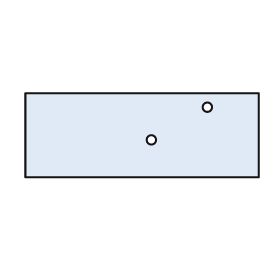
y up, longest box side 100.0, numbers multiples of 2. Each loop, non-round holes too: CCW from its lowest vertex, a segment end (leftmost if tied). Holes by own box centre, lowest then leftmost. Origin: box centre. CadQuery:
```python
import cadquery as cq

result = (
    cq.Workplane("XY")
    .moveTo(-50.0, -18.0)
    .lineTo(50.0, -18.0)
    .lineTo(50.0, 18.0)
    .lineTo(-50.0, 18.0)
    .close()
    .moveTo(4.0, -2.0)
    .circle(2.0)
    .moveTo(28.0, 12.0)
    .circle(2.0)
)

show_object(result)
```